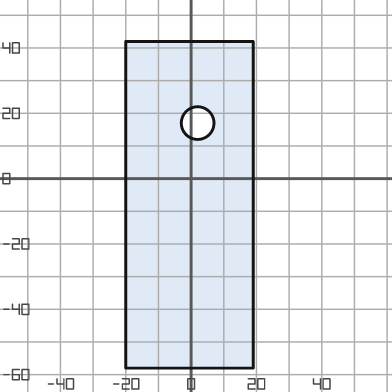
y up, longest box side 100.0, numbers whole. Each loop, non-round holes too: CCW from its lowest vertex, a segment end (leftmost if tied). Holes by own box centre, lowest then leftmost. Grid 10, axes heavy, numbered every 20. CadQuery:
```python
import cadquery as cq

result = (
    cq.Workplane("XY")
    .moveTo(-20.0, -58.0)
    .lineTo(19.0, -58.0)
    .lineTo(19.0, 42.0)
    .lineTo(-20.0, 42.0)
    .close()
    .moveTo(2.0, 17.0)
    .circle(5.0)
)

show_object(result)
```